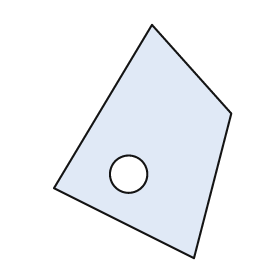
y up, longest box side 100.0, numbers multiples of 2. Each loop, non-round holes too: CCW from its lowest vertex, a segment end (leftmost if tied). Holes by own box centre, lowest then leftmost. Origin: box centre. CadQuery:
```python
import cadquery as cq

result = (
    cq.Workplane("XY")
    .moveTo(22.0, -50.0)
    .lineTo(38.0, 12.0)
    .lineTo(4.0, 50.0)
    .lineTo(-38.0, -20.0)
    .close()
    .moveTo(-6.0, -14.0)
    .circle(8.0)
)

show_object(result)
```